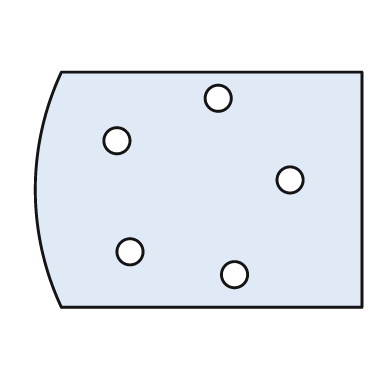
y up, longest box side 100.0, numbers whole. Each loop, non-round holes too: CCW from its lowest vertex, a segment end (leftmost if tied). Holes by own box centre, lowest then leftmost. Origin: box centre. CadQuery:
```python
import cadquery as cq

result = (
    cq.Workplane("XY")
    .moveTo(-42.0, -36.0)
    .lineTo(50.0, -36.0)
    .lineTo(50.0, 36.0)
    .lineTo(-42.0, 36.0)
    .threePointArc((-50.0, 0.0), (-42.0, -36.0))
    .close()
    .moveTo(11.0, -26.0)
    .circle(4.0)
    .moveTo(-21.0, -19.0)
    .circle(4.0)
    .moveTo(28.0, 3.0)
    .circle(4.0)
    .moveTo(-25.0, 15.0)
    .circle(4.0)
    .moveTo(6.0, 28.0)
    .circle(4.0)
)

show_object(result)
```